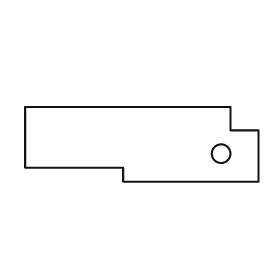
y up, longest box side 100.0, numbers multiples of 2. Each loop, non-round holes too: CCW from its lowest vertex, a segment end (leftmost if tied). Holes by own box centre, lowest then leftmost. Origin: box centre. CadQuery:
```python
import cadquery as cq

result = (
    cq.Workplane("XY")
    .moveTo(-8.0, -16.0)
    .lineTo(50.0, -16.0)
    .lineTo(50.0, 6.0)
    .lineTo(38.0, 6.0)
    .lineTo(38.0, 16.0)
    .lineTo(-50.0, 16.0)
    .lineTo(-50.0, -10.0)
    .lineTo(-8.0, -10.0)
    .close()
    .moveTo(34.0, -4.0)
    .circle(4.0)
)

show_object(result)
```